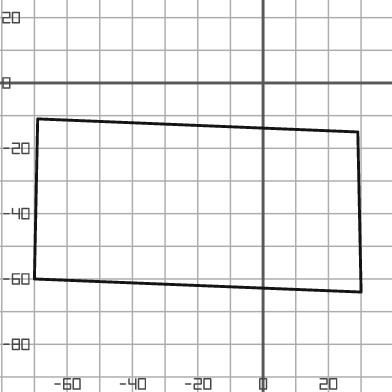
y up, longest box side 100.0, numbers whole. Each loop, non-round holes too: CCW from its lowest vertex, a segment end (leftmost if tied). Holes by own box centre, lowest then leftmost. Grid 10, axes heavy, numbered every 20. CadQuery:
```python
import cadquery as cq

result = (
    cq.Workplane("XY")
    .moveTo(30.0, -64.0)
    .lineTo(29.0, -15.0)
    .lineTo(-69.0, -11.0)
    .lineTo(-70.0, -60.0)
    .close()
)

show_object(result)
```